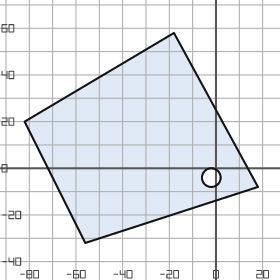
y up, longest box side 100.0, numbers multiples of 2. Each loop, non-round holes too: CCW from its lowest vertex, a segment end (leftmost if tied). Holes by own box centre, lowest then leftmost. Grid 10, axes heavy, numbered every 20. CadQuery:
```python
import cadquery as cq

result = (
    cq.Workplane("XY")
    .moveTo(-56.0, -32.0)
    .lineTo(18.0, -8.0)
    .lineTo(-18.0, 58.0)
    .lineTo(-82.0, 20.0)
    .close()
    .moveTo(-2.0, -4.0)
    .circle(4.0)
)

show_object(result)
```